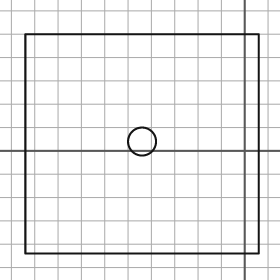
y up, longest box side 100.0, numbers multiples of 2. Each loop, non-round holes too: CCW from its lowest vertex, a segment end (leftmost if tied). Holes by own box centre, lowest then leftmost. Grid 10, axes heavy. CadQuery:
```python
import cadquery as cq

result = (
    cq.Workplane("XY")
    .moveTo(-94.0, -44.0)
    .lineTo(6.0, -44.0)
    .lineTo(6.0, 50.0)
    .lineTo(-94.0, 50.0)
    .close()
    .moveTo(-44.0, 4.0)
    .circle(6.0)
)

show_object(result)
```